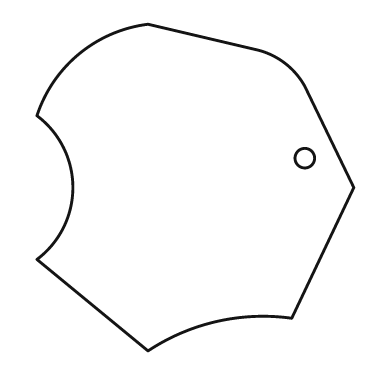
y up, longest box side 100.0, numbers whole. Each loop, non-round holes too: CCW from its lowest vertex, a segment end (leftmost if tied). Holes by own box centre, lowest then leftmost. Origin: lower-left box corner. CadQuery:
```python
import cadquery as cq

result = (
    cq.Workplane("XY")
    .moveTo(34.0, 0.0)
    .threePointArc((55.0, 9.0), (78.0, 10.0))
    .lineTo(97.0, 50.0)
    .lineTo(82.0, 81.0)
    .threePointArc((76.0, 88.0), (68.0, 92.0))
    .lineTo(34.0, 100.0)
    .threePointArc((13.0, 91.0), (0.0, 72.0))
    .threePointArc((11.0, 50.0), (0.0, 28.0))
    .close()
    .moveTo(82.0, 59.0)
    .circle(3.0)
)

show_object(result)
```